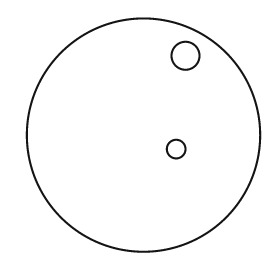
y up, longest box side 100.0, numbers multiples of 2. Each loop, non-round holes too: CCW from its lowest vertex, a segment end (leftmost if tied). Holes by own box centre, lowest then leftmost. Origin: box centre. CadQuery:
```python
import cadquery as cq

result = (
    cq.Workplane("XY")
    .moveTo(0.0, 0.0)
    .circle(50.0)
    .moveTo(14.0, -6.0)
    .circle(4.0)
    .moveTo(18.0, 34.0)
    .circle(6.0)
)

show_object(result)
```